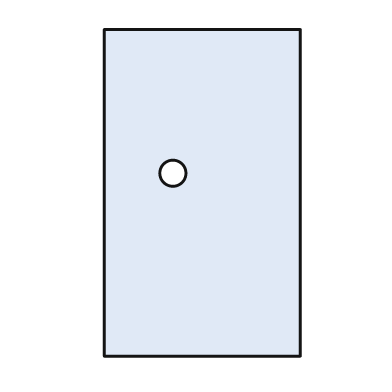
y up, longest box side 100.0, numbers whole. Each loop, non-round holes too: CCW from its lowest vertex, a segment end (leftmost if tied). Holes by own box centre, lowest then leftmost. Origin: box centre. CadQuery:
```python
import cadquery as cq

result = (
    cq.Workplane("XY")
    .moveTo(-30.0, -50.0)
    .lineTo(30.0, -50.0)
    .lineTo(30.0, 50.0)
    .lineTo(-30.0, 50.0)
    .close()
    .moveTo(-9.0, 6.0)
    .circle(4.0)
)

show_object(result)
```